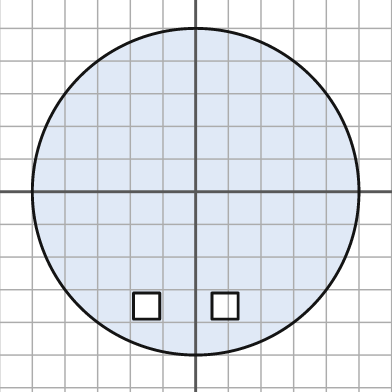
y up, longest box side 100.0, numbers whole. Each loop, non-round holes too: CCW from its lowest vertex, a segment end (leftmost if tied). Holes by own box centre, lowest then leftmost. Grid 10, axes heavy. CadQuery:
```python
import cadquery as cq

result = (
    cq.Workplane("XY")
    .moveTo(0.0, 0.0)
    .circle(50.0)
    .moveTo(-19.0, -39.0)
    .lineTo(-11.0, -39.0)
    .lineTo(-11.0, -31.0)
    .lineTo(-19.0, -31.0)
    .close()
    .moveTo(5.0, -39.0)
    .lineTo(13.0, -39.0)
    .lineTo(13.0, -31.0)
    .lineTo(5.0, -31.0)
    .close()
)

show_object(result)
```